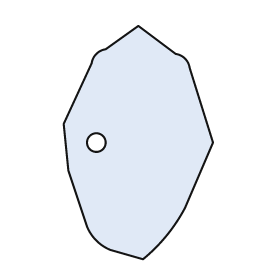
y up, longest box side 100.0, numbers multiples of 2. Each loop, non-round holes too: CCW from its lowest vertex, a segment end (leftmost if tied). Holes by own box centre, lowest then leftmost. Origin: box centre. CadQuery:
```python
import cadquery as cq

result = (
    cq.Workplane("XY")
    .moveTo(2.0, -50.0)
    .threePointArc((12.0, -40.0), (20.0, -28.0))
    .lineTo(32.0, 0.0)
    .lineTo(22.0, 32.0)
    .threePointArc((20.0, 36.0), (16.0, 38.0))
    .lineTo(0.0, 50.0)
    .lineTo(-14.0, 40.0)
    .threePointArc((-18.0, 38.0), (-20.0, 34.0))
    .lineTo(-32.0, 8.0)
    .lineTo(-30.0, -12.0)
    .lineTo(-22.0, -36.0)
    .threePointArc((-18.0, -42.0), (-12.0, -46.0))
    .close()
    .moveTo(-18.0, 0.0)
    .circle(4.0)
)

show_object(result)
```